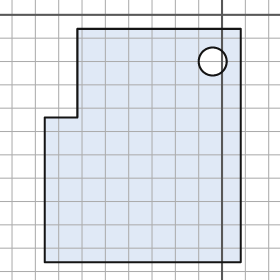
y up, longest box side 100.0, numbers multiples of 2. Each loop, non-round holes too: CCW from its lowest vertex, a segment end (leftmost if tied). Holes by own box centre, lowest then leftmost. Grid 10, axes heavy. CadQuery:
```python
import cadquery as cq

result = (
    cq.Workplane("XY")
    .moveTo(-76.0, -106.0)
    .lineTo(8.0, -106.0)
    .lineTo(8.0, -6.0)
    .lineTo(-62.0, -6.0)
    .lineTo(-62.0, -44.0)
    .lineTo(-76.0, -44.0)
    .close()
    .moveTo(-4.0, -20.0)
    .circle(6.0)
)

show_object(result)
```